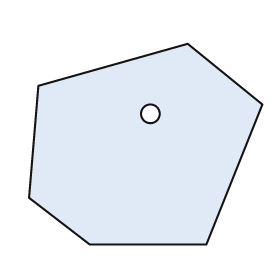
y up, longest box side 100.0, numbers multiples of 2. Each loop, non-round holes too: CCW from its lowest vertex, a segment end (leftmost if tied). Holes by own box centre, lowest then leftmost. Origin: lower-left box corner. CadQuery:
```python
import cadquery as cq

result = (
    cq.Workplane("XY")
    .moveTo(26.0, 0.0)
    .lineTo(76.0, 0.0)
    .lineTo(100.0, 60.0)
    .lineTo(68.0, 86.0)
    .lineTo(4.0, 68.0)
    .lineTo(0.0, 20.0)
    .close()
    .moveTo(52.0, 56.0)
    .circle(4.0)
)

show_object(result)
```